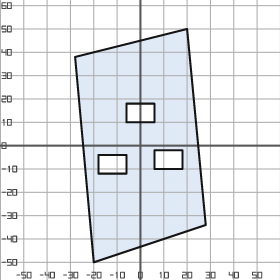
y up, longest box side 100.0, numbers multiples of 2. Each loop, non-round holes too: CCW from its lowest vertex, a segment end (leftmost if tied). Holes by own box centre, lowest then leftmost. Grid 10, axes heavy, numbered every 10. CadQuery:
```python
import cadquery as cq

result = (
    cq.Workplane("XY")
    .moveTo(-20.0, -50.0)
    .lineTo(28.0, -34.0)
    .lineTo(20.0, 50.0)
    .lineTo(-28.0, 38.0)
    .close()
    .moveTo(-18.0, -12.0)
    .lineTo(-6.0, -12.0)
    .lineTo(-6.0, -4.0)
    .lineTo(-18.0, -4.0)
    .close()
    .moveTo(6.0, -10.0)
    .lineTo(18.0, -10.0)
    .lineTo(18.0, -2.0)
    .lineTo(6.0, -2.0)
    .close()
    .moveTo(-6.0, 10.0)
    .lineTo(6.0, 10.0)
    .lineTo(6.0, 18.0)
    .lineTo(-6.0, 18.0)
    .close()
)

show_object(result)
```